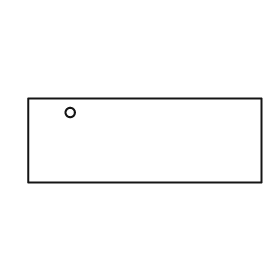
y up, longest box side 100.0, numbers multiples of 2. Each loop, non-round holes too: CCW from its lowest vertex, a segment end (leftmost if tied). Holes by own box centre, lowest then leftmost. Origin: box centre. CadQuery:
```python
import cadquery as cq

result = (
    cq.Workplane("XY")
    .moveTo(-50.0, -18.0)
    .lineTo(50.0, -18.0)
    .lineTo(50.0, 18.0)
    .lineTo(-50.0, 18.0)
    .close()
    .moveTo(-32.0, 12.0)
    .circle(2.0)
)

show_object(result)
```